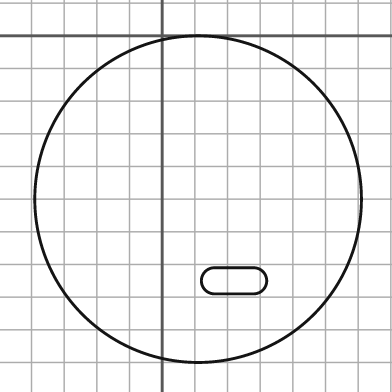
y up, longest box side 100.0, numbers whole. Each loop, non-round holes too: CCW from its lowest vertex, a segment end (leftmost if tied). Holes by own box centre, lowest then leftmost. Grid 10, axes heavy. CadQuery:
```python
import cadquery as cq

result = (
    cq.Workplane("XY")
    .moveTo(11.0, -50.0)
    .circle(50.0)
    .moveTo(16.0, -79.0)
    .lineTo(28.0, -79.0)
    .threePointArc((32.0, -75.0), (28.0, -71.0))
    .lineTo(16.0, -71.0)
    .threePointArc((12.0, -75.0), (16.0, -79.0))
    .close()
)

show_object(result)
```